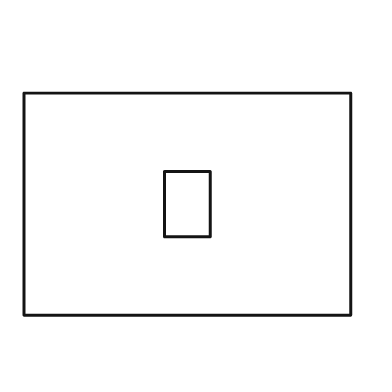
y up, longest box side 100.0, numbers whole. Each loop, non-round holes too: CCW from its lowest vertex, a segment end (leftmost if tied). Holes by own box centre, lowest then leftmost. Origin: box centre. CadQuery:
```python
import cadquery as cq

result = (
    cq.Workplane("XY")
    .moveTo(-50.0, -34.0)
    .lineTo(50.0, -34.0)
    .lineTo(50.0, 34.0)
    .lineTo(-50.0, 34.0)
    .close()
    .moveTo(-7.0, -10.0)
    .lineTo(7.0, -10.0)
    .lineTo(7.0, 10.0)
    .lineTo(-7.0, 10.0)
    .close()
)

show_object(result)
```